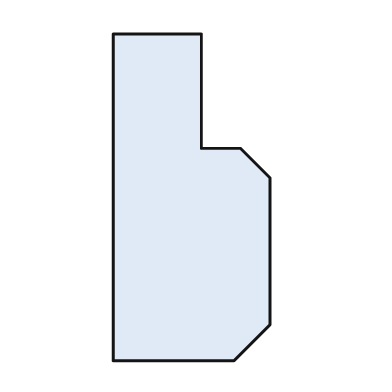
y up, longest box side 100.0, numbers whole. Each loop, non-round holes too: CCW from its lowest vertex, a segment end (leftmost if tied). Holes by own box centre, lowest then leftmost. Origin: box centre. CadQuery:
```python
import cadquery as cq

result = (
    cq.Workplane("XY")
    .moveTo(-24.0, -50.0)
    .lineTo(13.0, -50.0)
    .lineTo(24.0, -39.0)
    .lineTo(24.0, 6.0)
    .lineTo(15.0, 15.0)
    .lineTo(3.0, 15.0)
    .lineTo(3.0, 50.0)
    .lineTo(-24.0, 50.0)
    .close()
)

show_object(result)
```